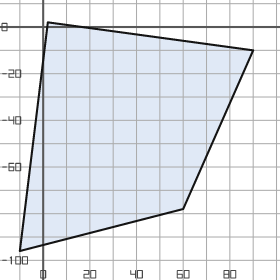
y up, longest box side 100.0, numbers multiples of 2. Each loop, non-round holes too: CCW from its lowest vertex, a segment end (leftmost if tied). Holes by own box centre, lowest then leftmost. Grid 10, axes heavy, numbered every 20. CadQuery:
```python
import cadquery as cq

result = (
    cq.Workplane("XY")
    .moveTo(-10.0, -96.0)
    .lineTo(60.0, -78.0)
    .lineTo(90.0, -10.0)
    .lineTo(2.0, 2.0)
    .close()
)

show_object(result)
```